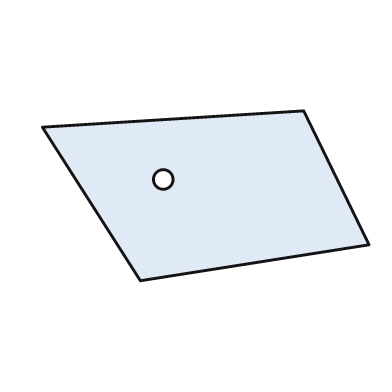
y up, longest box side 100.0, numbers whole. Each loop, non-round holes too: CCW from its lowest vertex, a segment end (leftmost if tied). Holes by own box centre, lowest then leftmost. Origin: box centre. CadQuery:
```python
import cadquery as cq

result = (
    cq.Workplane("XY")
    .moveTo(-20.0, -26.0)
    .lineTo(50.0, -15.0)
    .lineTo(30.0, 26.0)
    .lineTo(-50.0, 21.0)
    .close()
    .moveTo(-13.0, 5.0)
    .circle(3.0)
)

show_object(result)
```